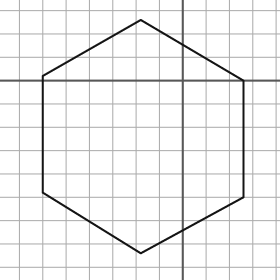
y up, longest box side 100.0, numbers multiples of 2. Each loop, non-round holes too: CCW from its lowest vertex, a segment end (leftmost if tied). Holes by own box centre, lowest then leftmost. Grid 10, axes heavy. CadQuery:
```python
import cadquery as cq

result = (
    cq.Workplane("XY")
    .moveTo(-18.0, -74.0)
    .lineTo(26.0, -50.0)
    .lineTo(26.0, 0.0)
    .lineTo(-18.0, 26.0)
    .lineTo(-60.0, 2.0)
    .lineTo(-60.0, -48.0)
    .close()
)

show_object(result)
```